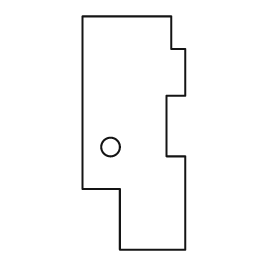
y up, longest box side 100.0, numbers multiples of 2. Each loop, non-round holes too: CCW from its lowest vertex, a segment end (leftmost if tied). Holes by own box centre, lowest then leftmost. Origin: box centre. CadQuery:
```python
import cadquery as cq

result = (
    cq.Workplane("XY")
    .moveTo(-6.0, -50.0)
    .lineTo(22.0, -50.0)
    .lineTo(22.0, -10.0)
    .lineTo(14.0, -10.0)
    .lineTo(14.0, 16.0)
    .lineTo(22.0, 16.0)
    .lineTo(22.0, 36.0)
    .lineTo(16.0, 36.0)
    .lineTo(16.0, 50.0)
    .lineTo(-22.0, 50.0)
    .lineTo(-22.0, -24.0)
    .lineTo(-6.0, -24.0)
    .close()
    .moveTo(-10.0, -6.0)
    .circle(4.0)
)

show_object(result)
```